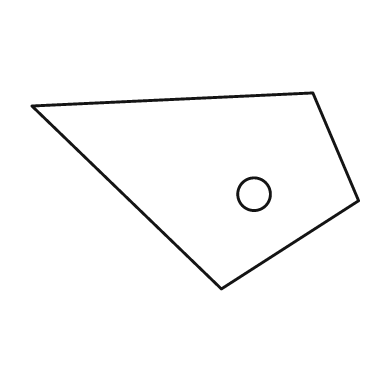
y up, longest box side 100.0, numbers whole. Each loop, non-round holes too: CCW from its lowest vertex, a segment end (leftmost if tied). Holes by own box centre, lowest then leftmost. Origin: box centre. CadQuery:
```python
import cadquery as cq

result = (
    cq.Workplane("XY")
    .moveTo(8.0, -30.0)
    .lineTo(50.0, -3.0)
    .lineTo(36.0, 30.0)
    .lineTo(-50.0, 26.0)
    .close()
    .moveTo(18.0, -1.0)
    .circle(5.0)
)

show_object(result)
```